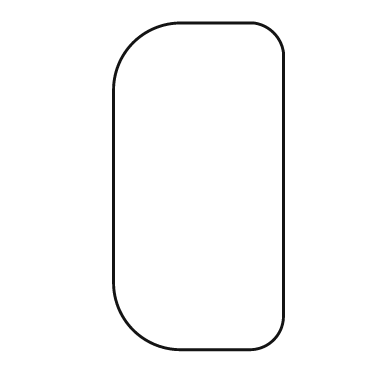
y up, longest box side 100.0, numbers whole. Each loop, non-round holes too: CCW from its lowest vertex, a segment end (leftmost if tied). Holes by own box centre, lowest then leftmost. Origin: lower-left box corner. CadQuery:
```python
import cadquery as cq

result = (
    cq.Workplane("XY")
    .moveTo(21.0, 0.0)
    .lineTo(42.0, 0.0)
    .threePointArc((49.0, 3.0), (52.0, 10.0))
    .lineTo(52.0, 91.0)
    .threePointArc((49.0, 97.0), (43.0, 100.0))
    .lineTo(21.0, 100.0)
    .threePointArc((6.0, 94.0), (0.0, 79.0))
    .lineTo(0.0, 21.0)
    .threePointArc((6.0, 6.0), (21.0, 0.0))
    .close()
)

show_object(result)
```